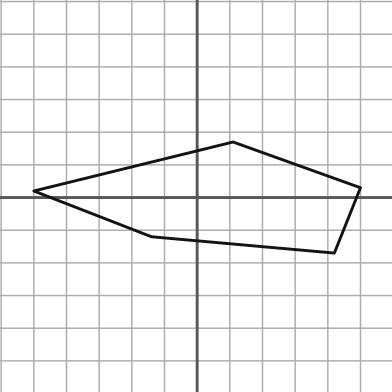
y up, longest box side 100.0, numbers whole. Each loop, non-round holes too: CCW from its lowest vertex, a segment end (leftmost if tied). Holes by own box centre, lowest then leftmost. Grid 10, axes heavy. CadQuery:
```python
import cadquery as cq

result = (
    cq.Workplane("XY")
    .moveTo(42.0, -17.0)
    .lineTo(50.0, 3.0)
    .lineTo(11.0, 17.0)
    .lineTo(-50.0, 2.0)
    .lineTo(-14.0, -12.0)
    .close()
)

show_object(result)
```